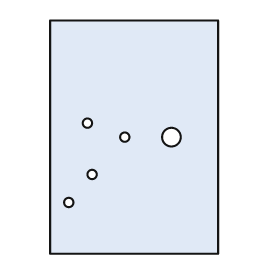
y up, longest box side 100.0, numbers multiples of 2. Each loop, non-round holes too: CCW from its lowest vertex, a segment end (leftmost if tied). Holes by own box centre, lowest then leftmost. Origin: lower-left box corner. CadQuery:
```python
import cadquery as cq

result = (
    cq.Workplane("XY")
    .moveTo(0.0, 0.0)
    .lineTo(72.0, 0.0)
    .lineTo(72.0, 100.0)
    .lineTo(0.0, 100.0)
    .close()
    .moveTo(8.0, 22.0)
    .circle(2.0)
    .moveTo(18.0, 34.0)
    .circle(2.0)
    .moveTo(32.0, 50.0)
    .circle(2.0)
    .moveTo(52.0, 50.0)
    .circle(4.0)
    .moveTo(16.0, 56.0)
    .circle(2.0)
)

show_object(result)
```